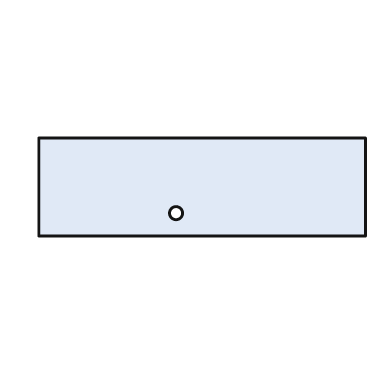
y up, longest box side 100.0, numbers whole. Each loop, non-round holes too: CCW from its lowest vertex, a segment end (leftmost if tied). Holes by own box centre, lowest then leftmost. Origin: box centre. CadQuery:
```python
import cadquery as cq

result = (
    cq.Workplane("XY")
    .moveTo(-50.0, -15.0)
    .lineTo(50.0, -15.0)
    .lineTo(50.0, 15.0)
    .lineTo(-50.0, 15.0)
    .close()
    .moveTo(-8.0, -8.0)
    .circle(2.0)
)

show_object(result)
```